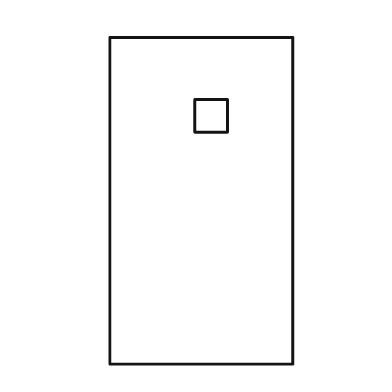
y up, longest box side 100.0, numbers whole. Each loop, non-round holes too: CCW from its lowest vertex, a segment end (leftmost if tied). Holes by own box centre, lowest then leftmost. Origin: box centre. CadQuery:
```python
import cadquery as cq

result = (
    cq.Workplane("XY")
    .moveTo(-28.0, -50.0)
    .lineTo(28.0, -50.0)
    .lineTo(28.0, 50.0)
    .lineTo(-28.0, 50.0)
    .close()
    .moveTo(-2.0, 21.0)
    .lineTo(8.0, 21.0)
    .lineTo(8.0, 31.0)
    .lineTo(-2.0, 31.0)
    .close()
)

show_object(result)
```